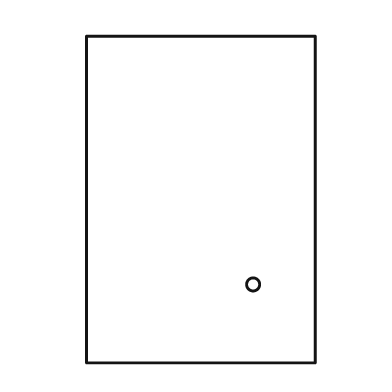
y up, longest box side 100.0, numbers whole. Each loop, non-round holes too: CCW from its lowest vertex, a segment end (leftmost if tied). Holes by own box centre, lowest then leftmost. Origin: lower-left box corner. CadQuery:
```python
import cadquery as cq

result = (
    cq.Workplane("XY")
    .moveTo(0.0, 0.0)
    .lineTo(70.0, 0.0)
    .lineTo(70.0, 100.0)
    .lineTo(0.0, 100.0)
    .close()
    .moveTo(51.0, 24.0)
    .circle(2.0)
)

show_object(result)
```